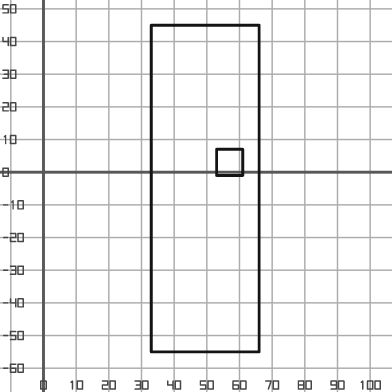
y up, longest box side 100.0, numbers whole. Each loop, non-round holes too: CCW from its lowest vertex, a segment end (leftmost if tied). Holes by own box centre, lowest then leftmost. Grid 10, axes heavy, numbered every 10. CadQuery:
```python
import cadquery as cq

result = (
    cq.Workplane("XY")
    .moveTo(33.0, -55.0)
    .lineTo(66.0, -55.0)
    .lineTo(66.0, 45.0)
    .lineTo(33.0, 45.0)
    .close()
    .moveTo(53.0, -1.0)
    .lineTo(61.0, -1.0)
    .lineTo(61.0, 7.0)
    .lineTo(53.0, 7.0)
    .close()
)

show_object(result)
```